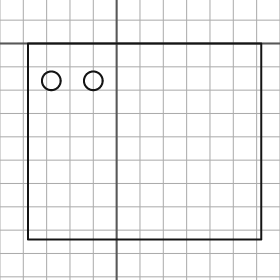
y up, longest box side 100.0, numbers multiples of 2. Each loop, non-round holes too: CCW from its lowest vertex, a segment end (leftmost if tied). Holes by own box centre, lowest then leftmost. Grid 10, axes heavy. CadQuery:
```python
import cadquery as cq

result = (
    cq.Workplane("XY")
    .moveTo(-38.0, -84.0)
    .lineTo(62.0, -84.0)
    .lineTo(62.0, 0.0)
    .lineTo(-38.0, 0.0)
    .close()
    .moveTo(-28.0, -16.0)
    .circle(4.0)
    .moveTo(-10.0, -16.0)
    .circle(4.0)
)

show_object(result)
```